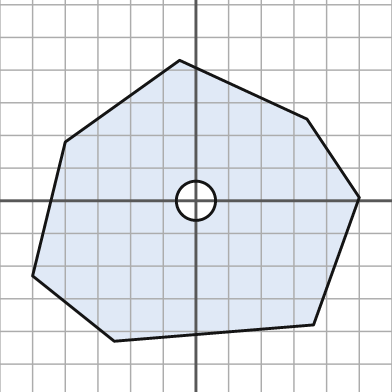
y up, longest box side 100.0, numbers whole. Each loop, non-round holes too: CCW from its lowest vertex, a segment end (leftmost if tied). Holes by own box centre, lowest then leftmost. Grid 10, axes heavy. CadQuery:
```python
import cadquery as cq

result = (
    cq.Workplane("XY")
    .moveTo(-25.0, -43.0)
    .lineTo(36.0, -38.0)
    .lineTo(50.0, 1.0)
    .lineTo(34.0, 25.0)
    .lineTo(-5.0, 43.0)
    .lineTo(-40.0, 18.0)
    .lineTo(-50.0, -23.0)
    .close()
    .moveTo(0.0, 0.0)
    .circle(6.0)
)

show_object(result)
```